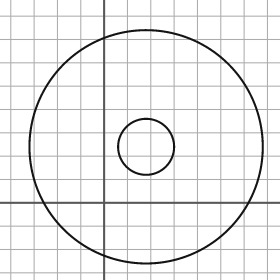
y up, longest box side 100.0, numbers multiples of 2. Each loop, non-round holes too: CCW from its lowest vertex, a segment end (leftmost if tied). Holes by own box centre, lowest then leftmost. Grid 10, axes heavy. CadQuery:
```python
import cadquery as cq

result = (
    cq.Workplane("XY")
    .moveTo(18.0, 24.0)
    .circle(50.0)
    .moveTo(18.0, 24.0)
    .circle(12.0)
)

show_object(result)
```